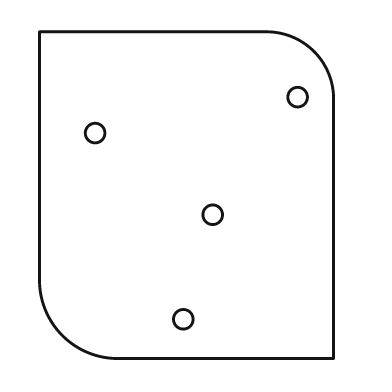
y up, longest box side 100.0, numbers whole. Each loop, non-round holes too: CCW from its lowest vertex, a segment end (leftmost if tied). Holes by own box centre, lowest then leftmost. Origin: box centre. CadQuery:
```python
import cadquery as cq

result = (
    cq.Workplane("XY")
    .moveTo(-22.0, -50.0)
    .lineTo(45.0, -50.0)
    .lineTo(45.0, 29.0)
    .threePointArc((39.0, 44.0), (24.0, 50.0))
    .lineTo(-45.0, 50.0)
    .lineTo(-45.0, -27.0)
    .threePointArc((-38.0, -43.0), (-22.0, -50.0))
    .close()
    .moveTo(-1.0, -38.0)
    .circle(3.0)
    .moveTo(8.0, -6.0)
    .circle(3.0)
    .moveTo(-28.0, 19.0)
    .circle(3.0)
    .moveTo(34.0, 30.0)
    .circle(3.0)
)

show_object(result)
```